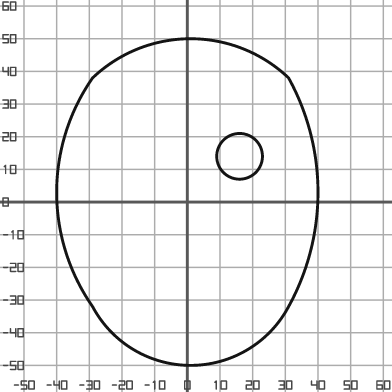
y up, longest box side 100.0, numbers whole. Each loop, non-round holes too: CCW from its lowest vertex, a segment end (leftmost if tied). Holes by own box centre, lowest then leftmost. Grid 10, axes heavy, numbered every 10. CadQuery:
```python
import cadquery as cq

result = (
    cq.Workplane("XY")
    .moveTo(-29.0, -32.0)
    .threePointArc((1.0, -50.0), (31.0, -32.0))
    .threePointArc((40.0, 3.0), (31.0, 38.0))
    .threePointArc((1.0, 50.0), (-29.0, 38.0))
    .threePointArc((-40.0, 3.0), (-29.0, -32.0))
    .close()
    .moveTo(16.0, 14.0)
    .circle(7.0)
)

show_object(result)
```